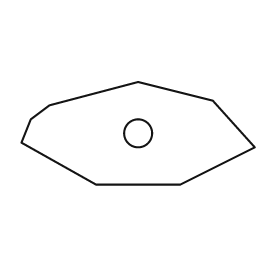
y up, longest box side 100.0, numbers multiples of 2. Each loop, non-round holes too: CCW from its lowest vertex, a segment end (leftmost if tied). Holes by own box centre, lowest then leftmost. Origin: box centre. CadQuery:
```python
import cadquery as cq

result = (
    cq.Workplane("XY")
    .moveTo(-18.0, -22.0)
    .lineTo(18.0, -22.0)
    .lineTo(50.0, -6.0)
    .lineTo(32.0, 14.0)
    .lineTo(0.0, 22.0)
    .lineTo(-38.0, 12.0)
    .lineTo(-46.0, 6.0)
    .lineTo(-50.0, -4.0)
    .close()
    .moveTo(0.0, 0.0)
    .circle(6.0)
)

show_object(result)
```